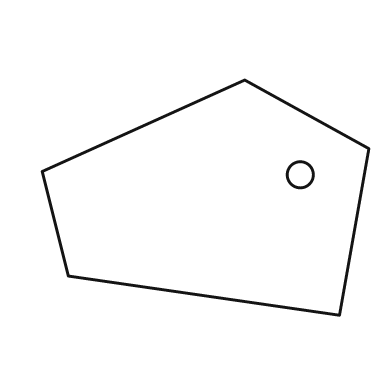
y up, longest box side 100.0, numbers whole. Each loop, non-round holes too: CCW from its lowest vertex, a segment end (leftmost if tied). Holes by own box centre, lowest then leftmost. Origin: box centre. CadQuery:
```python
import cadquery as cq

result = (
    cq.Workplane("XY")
    .moveTo(41.0, -36.0)
    .lineTo(50.0, 15.0)
    .lineTo(12.0, 36.0)
    .lineTo(-50.0, 8.0)
    .lineTo(-42.0, -24.0)
    .close()
    .moveTo(29.0, 7.0)
    .circle(4.0)
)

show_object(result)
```